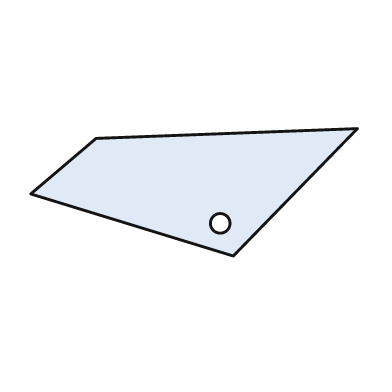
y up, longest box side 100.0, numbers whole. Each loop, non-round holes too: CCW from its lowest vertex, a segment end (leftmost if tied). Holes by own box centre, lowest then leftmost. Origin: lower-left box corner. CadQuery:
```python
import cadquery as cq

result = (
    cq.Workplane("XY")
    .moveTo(62.0, 0.0)
    .lineTo(100.0, 39.0)
    .lineTo(20.0, 36.0)
    .lineTo(0.0, 19.0)
    .close()
    .moveTo(58.0, 10.0)
    .circle(3.0)
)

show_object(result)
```